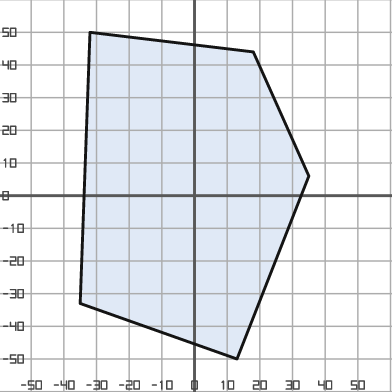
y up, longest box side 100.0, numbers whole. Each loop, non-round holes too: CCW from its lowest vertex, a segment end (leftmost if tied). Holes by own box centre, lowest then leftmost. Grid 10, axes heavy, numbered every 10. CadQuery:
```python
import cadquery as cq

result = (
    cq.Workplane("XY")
    .moveTo(13.0, -50.0)
    .lineTo(35.0, 6.0)
    .lineTo(18.0, 44.0)
    .lineTo(-32.0, 50.0)
    .lineTo(-35.0, -33.0)
    .close()
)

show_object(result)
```